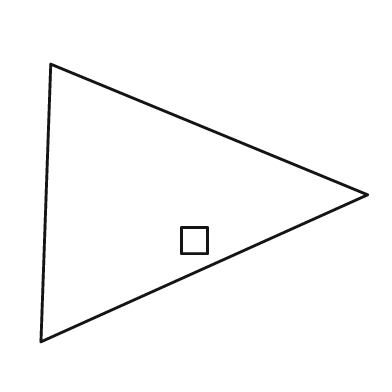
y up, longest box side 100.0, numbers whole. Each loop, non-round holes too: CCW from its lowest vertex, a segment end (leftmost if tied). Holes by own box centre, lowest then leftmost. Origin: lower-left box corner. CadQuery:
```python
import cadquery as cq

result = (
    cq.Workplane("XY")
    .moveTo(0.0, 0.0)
    .lineTo(100.0, 45.0)
    .lineTo(3.0, 85.0)
    .close()
    .moveTo(43.0, 27.0)
    .lineTo(51.0, 27.0)
    .lineTo(51.0, 35.0)
    .lineTo(43.0, 35.0)
    .close()
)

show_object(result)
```